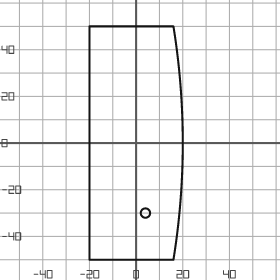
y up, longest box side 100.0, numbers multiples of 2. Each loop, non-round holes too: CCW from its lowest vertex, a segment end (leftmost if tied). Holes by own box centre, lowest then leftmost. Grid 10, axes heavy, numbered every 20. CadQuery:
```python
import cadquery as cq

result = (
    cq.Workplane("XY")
    .moveTo(-20.0, -50.0)
    .lineTo(16.0, -50.0)
    .threePointArc((20.0, 0.0), (16.0, 50.0))
    .lineTo(-20.0, 50.0)
    .close()
    .moveTo(4.0, -30.0)
    .circle(2.0)
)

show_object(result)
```